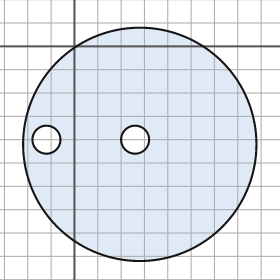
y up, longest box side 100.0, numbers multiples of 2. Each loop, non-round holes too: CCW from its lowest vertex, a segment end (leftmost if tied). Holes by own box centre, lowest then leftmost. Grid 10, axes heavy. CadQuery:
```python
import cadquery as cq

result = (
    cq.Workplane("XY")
    .moveTo(28.0, -42.0)
    .circle(50.0)
    .moveTo(-12.0, -40.0)
    .circle(6.0)
    .moveTo(26.0, -40.0)
    .circle(6.0)
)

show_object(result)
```